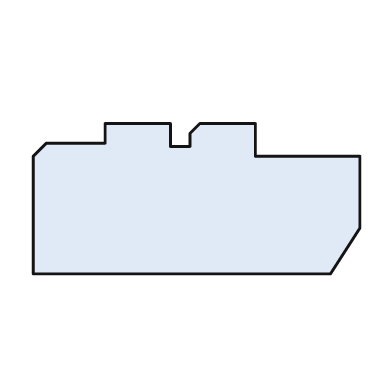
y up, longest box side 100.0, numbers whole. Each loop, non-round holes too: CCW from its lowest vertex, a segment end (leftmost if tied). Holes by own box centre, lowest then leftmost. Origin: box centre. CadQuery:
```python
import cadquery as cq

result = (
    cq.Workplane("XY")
    .moveTo(-50.0, -23.0)
    .lineTo(41.0, -23.0)
    .lineTo(50.0, -9.0)
    .lineTo(50.0, 13.0)
    .lineTo(18.0, 13.0)
    .lineTo(18.0, 23.0)
    .lineTo(1.0, 23.0)
    .lineTo(-2.0, 20.0)
    .lineTo(-2.0, 16.0)
    .lineTo(-8.0, 16.0)
    .lineTo(-8.0, 23.0)
    .lineTo(-28.0, 23.0)
    .lineTo(-28.0, 17.0)
    .lineTo(-46.0, 17.0)
    .lineTo(-50.0, 13.0)
    .close()
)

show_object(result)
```